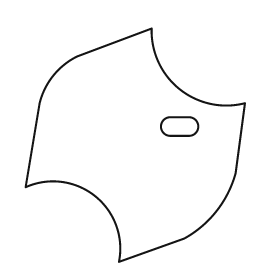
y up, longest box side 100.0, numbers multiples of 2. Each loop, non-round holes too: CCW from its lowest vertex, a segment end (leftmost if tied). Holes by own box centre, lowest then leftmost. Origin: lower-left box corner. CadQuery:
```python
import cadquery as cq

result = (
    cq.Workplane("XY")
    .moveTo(40.0, 0.0)
    .lineTo(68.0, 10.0)
    .threePointArc((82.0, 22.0), (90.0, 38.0))
    .lineTo(94.0, 68.0)
    .threePointArc((66.0, 74.0), (54.0, 100.0))
    .lineTo(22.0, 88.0)
    .threePointArc((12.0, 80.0), (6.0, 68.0))
    .lineTo(0.0, 32.0)
    .threePointArc((30.0, 28.0), (40.0, 0.0))
    .close()
    .moveTo(62.0, 54.0)
    .lineTo(70.0, 54.0)
    .threePointArc((74.0, 58.0), (70.0, 62.0))
    .lineTo(62.0, 62.0)
    .threePointArc((58.0, 58.0), (62.0, 54.0))
    .close()
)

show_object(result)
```